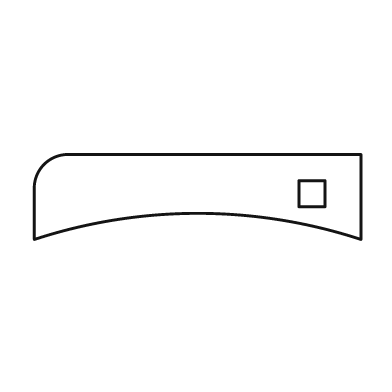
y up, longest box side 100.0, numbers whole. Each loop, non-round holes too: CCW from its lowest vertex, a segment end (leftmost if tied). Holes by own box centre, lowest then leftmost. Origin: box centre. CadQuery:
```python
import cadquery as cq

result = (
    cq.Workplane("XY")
    .moveTo(-50.0, -13.0)
    .threePointArc((0.0, -5.0), (50.0, -13.0))
    .lineTo(50.0, 13.0)
    .lineTo(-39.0, 13.0)
    .threePointArc((-47.0, 10.0), (-50.0, 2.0))
    .close()
    .moveTo(31.0, -3.0)
    .lineTo(39.0, -3.0)
    .lineTo(39.0, 5.0)
    .lineTo(31.0, 5.0)
    .close()
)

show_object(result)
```